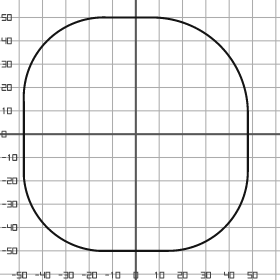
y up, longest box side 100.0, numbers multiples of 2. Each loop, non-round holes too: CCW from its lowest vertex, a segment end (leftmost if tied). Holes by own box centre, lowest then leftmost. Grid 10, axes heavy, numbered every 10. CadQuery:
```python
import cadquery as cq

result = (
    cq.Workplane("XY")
    .moveTo(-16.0, -50.0)
    .lineTo(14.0, -50.0)
    .threePointArc((38.0, -40.0), (48.0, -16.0))
    .lineTo(48.0, 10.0)
    .threePointArc((36.0, 38.0), (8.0, 50.0))
    .lineTo(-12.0, 50.0)
    .threePointArc((-38.0, 40.0), (-48.0, 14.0))
    .lineTo(-48.0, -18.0)
    .threePointArc((-38.0, -40.0), (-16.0, -50.0))
    .close()
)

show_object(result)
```